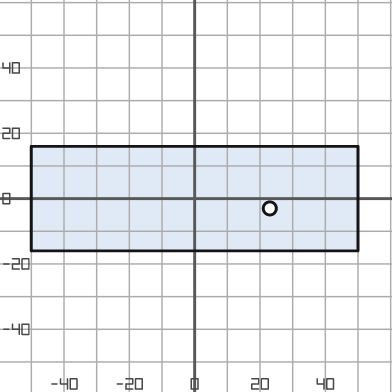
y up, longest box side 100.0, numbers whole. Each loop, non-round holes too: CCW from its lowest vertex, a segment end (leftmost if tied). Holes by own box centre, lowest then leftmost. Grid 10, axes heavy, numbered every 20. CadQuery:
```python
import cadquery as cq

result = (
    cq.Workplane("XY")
    .moveTo(-50.0, -16.0)
    .lineTo(50.0, -16.0)
    .lineTo(50.0, 16.0)
    .lineTo(-50.0, 16.0)
    .close()
    .moveTo(23.0, -3.0)
    .circle(2.0)
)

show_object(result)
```